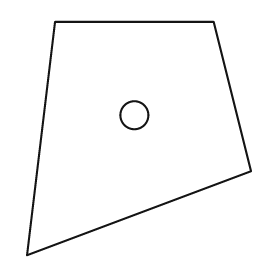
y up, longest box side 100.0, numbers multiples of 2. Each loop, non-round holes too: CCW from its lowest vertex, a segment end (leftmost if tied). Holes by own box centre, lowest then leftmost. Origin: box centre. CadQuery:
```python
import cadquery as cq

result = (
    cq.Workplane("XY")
    .moveTo(-48.0, -50.0)
    .lineTo(48.0, -14.0)
    .lineTo(32.0, 50.0)
    .lineTo(-36.0, 50.0)
    .close()
    .moveTo(-2.0, 10.0)
    .circle(6.0)
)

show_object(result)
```